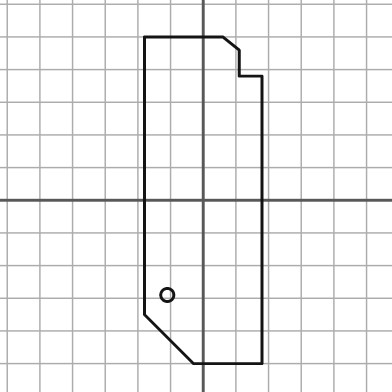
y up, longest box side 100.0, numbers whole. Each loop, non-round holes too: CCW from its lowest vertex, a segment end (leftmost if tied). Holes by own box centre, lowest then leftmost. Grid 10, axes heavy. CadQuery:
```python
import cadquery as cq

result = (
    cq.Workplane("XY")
    .moveTo(-3.0, -50.0)
    .lineTo(18.0, -50.0)
    .lineTo(18.0, 38.0)
    .lineTo(11.0, 38.0)
    .lineTo(11.0, 46.0)
    .lineTo(6.0, 50.0)
    .lineTo(-18.0, 50.0)
    .lineTo(-18.0, -35.0)
    .close()
    .moveTo(-11.0, -29.0)
    .circle(2.0)
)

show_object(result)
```